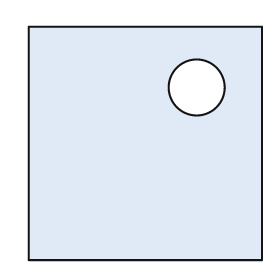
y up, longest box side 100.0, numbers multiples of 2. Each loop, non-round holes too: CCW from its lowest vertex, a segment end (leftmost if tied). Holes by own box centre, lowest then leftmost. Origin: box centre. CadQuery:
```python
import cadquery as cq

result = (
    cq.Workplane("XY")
    .moveTo(-50.0, -50.0)
    .lineTo(50.0, -50.0)
    .lineTo(50.0, 50.0)
    .lineTo(-50.0, 50.0)
    .close()
    .moveTo(22.0, 24.0)
    .circle(12.0)
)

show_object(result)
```